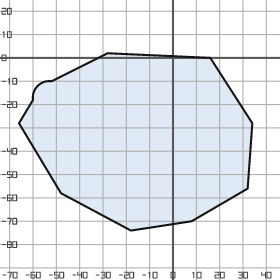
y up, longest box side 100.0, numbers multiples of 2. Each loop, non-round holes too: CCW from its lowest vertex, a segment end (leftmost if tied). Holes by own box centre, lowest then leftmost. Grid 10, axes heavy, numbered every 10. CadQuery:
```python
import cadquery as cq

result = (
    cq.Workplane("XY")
    .moveTo(-18.0, -74.0)
    .lineTo(8.0, -70.0)
    .lineTo(32.0, -56.0)
    .lineTo(34.0, -28.0)
    .lineTo(16.0, 0.0)
    .lineTo(-28.0, 2.0)
    .lineTo(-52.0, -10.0)
    .threePointArc((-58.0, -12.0), (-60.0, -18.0))
    .lineTo(-66.0, -28.0)
    .lineTo(-48.0, -58.0)
    .close()
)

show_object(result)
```